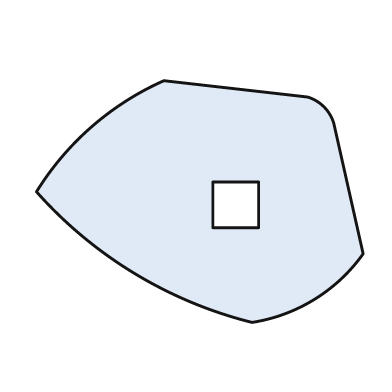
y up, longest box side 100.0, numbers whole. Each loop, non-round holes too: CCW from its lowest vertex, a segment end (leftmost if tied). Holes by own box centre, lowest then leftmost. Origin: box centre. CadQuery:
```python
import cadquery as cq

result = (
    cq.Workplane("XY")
    .moveTo(16.0, -37.0)
    .threePointArc((35.0, -30.0), (50.0, -16.0))
    .lineTo(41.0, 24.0)
    .threePointArc((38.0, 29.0), (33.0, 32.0))
    .lineTo(-11.0, 37.0)
    .threePointArc((-33.0, 23.0), (-50.0, 3.0))
    .threePointArc((-20.0, -22.0), (16.0, -37.0))
    .close()
    .moveTo(4.0, -8.0)
    .lineTo(18.0, -8.0)
    .lineTo(18.0, 6.0)
    .lineTo(4.0, 6.0)
    .close()
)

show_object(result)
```